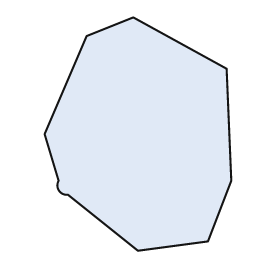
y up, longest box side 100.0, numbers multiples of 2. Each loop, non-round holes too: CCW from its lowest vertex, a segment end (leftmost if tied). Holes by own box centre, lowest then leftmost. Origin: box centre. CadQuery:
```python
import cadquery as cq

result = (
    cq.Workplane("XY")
    .moveTo(0.0, -50.0)
    .lineTo(30.0, -46.0)
    .lineTo(40.0, -20.0)
    .lineTo(38.0, 28.0)
    .lineTo(-2.0, 50.0)
    .lineTo(-22.0, 42.0)
    .lineTo(-40.0, 0.0)
    .lineTo(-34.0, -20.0)
    .threePointArc((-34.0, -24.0), (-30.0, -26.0))
    .close()
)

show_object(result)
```